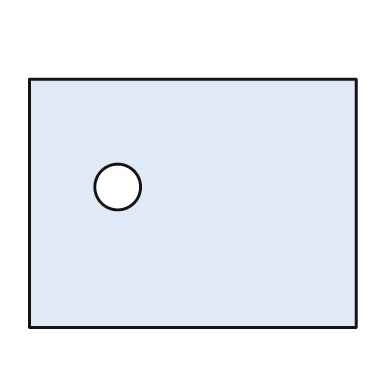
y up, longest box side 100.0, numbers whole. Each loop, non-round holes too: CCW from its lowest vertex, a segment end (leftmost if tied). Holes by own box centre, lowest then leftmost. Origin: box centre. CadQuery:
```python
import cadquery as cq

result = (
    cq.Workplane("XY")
    .moveTo(-50.0, -38.0)
    .lineTo(50.0, -38.0)
    .lineTo(50.0, 38.0)
    .lineTo(-50.0, 38.0)
    .close()
    .moveTo(-23.0, 5.0)
    .circle(7.0)
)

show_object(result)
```